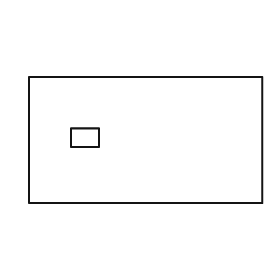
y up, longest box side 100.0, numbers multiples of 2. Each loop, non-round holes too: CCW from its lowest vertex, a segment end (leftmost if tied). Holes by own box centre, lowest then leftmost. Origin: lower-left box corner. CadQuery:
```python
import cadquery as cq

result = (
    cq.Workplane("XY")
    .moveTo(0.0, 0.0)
    .lineTo(100.0, 0.0)
    .lineTo(100.0, 54.0)
    .lineTo(0.0, 54.0)
    .close()
    .moveTo(18.0, 24.0)
    .lineTo(30.0, 24.0)
    .lineTo(30.0, 32.0)
    .lineTo(18.0, 32.0)
    .close()
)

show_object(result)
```